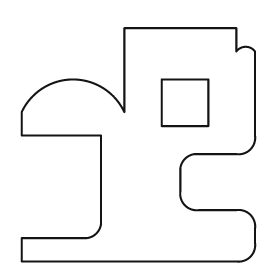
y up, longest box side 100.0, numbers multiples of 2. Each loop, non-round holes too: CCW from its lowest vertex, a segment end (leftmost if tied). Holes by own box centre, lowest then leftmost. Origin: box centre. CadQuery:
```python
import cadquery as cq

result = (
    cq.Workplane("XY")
    .moveTo(-50.0, -50.0)
    .lineTo(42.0, -50.0)
    .threePointArc((48.0, -48.0), (50.0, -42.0))
    .lineTo(50.0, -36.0)
    .threePointArc((48.0, -30.0), (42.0, -28.0))
    .lineTo(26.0, -28.0)
    .threePointArc((20.0, -26.0), (18.0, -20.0))
    .lineTo(18.0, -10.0)
    .threePointArc((20.0, -6.0), (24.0, -4.0))
    .lineTo(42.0, -4.0)
    .threePointArc((48.0, -2.0), (50.0, 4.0))
    .lineTo(50.0, 40.0)
    .threePointArc((46.0, 42.0), (42.0, 40.0))
    .lineTo(42.0, 50.0)
    .lineTo(-6.0, 50.0)
    .lineTo(-6.0, 14.0)
    .threePointArc((-28.0, 28.0), (-50.0, 14.0))
    .lineTo(-50.0, 4.0)
    .lineTo(-16.0, 4.0)
    .lineTo(-16.0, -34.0)
    .threePointArc((-18.0, -38.0), (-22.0, -40.0))
    .lineTo(-50.0, -40.0)
    .close()
    .moveTo(10.0, 8.0)
    .lineTo(30.0, 8.0)
    .lineTo(30.0, 28.0)
    .lineTo(10.0, 28.0)
    .close()
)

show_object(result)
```